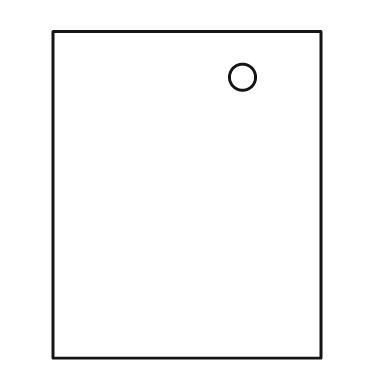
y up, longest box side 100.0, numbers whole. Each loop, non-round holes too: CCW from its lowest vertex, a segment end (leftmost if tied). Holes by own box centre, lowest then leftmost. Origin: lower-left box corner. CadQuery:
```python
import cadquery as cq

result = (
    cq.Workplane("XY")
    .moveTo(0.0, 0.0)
    .lineTo(82.0, 0.0)
    .lineTo(82.0, 100.0)
    .lineTo(0.0, 100.0)
    .close()
    .moveTo(58.0, 86.0)
    .circle(4.0)
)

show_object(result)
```